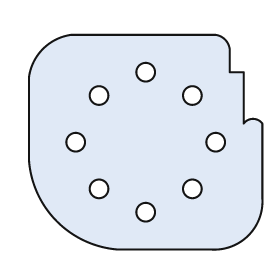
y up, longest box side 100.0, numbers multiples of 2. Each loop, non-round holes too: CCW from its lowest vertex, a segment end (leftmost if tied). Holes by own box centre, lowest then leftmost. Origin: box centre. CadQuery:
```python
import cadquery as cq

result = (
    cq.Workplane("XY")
    .moveTo(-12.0, -46.0)
    .lineTo(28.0, -46.0)
    .threePointArc((44.0, -40.0), (50.0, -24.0))
    .lineTo(50.0, 8.0)
    .threePointArc((46.0, 10.0), (42.0, 8.0))
    .lineTo(42.0, 30.0)
    .lineTo(36.0, 30.0)
    .lineTo(36.0, 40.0)
    .threePointArc((34.0, 44.0), (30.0, 46.0))
    .lineTo(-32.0, 46.0)
    .threePointArc((-44.0, 40.0), (-50.0, 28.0))
    .lineTo(-50.0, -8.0)
    .threePointArc((-38.0, -34.0), (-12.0, -46.0))
    .close()
    .moveTo(0.0, -30.0)
    .circle(4.0)
    .moveTo(-20.0, -20.0)
    .circle(4.0)
    .moveTo(20.0, -20.0)
    .circle(4.0)
    .moveTo(-30.0, 0.0)
    .circle(4.0)
    .moveTo(30.0, 0.0)
    .circle(4.0)
    .moveTo(-20.0, 20.0)
    .circle(4.0)
    .moveTo(20.0, 20.0)
    .circle(4.0)
    .moveTo(0.0, 30.0)
    .circle(4.0)
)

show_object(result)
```